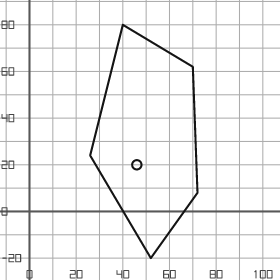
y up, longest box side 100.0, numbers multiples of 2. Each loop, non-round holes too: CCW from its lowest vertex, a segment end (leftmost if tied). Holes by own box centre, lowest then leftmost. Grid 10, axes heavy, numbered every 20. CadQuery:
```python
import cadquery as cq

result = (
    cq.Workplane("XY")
    .moveTo(52.0, -20.0)
    .lineTo(72.0, 8.0)
    .lineTo(70.0, 62.0)
    .lineTo(40.0, 80.0)
    .lineTo(26.0, 24.0)
    .close()
    .moveTo(46.0, 20.0)
    .circle(2.0)
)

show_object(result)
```